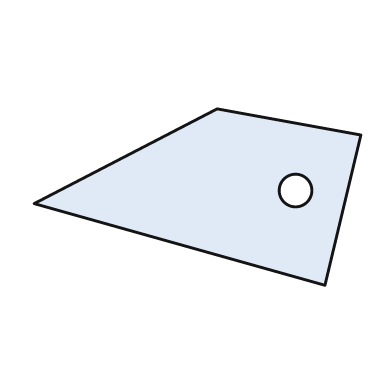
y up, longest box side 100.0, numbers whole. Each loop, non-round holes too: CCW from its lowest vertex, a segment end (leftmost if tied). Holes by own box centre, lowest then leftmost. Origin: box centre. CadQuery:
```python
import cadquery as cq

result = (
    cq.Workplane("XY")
    .moveTo(39.0, -27.0)
    .lineTo(50.0, 19.0)
    .lineTo(6.0, 27.0)
    .lineTo(-50.0, -2.0)
    .close()
    .moveTo(30.0, 2.0)
    .circle(5.0)
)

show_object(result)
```